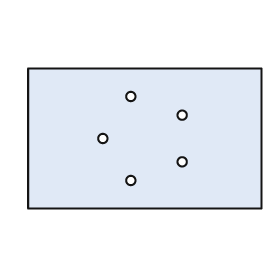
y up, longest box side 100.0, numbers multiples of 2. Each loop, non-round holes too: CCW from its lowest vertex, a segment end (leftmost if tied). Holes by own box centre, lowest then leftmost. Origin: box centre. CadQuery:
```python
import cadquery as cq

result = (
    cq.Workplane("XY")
    .moveTo(-50.0, -30.0)
    .lineTo(50.0, -30.0)
    .lineTo(50.0, 30.0)
    .lineTo(-50.0, 30.0)
    .close()
    .moveTo(-6.0, -18.0)
    .circle(2.0)
    .moveTo(16.0, -10.0)
    .circle(2.0)
    .moveTo(-18.0, 0.0)
    .circle(2.0)
    .moveTo(16.0, 10.0)
    .circle(2.0)
    .moveTo(-6.0, 18.0)
    .circle(2.0)
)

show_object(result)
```